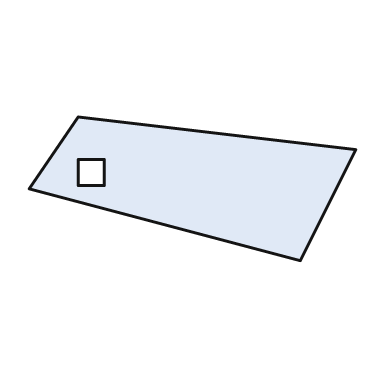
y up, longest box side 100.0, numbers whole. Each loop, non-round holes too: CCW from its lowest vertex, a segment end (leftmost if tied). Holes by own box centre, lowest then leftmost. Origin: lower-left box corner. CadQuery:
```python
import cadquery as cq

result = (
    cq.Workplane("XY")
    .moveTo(83.0, 0.0)
    .lineTo(100.0, 34.0)
    .lineTo(15.0, 44.0)
    .lineTo(0.0, 22.0)
    .close()
    .moveTo(15.0, 23.0)
    .lineTo(23.0, 23.0)
    .lineTo(23.0, 31.0)
    .lineTo(15.0, 31.0)
    .close()
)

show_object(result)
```